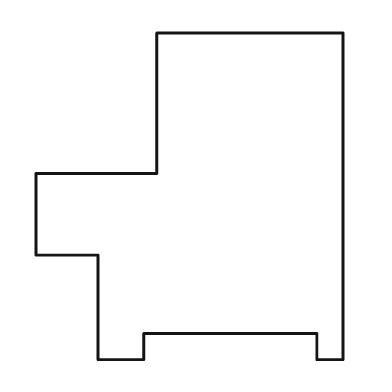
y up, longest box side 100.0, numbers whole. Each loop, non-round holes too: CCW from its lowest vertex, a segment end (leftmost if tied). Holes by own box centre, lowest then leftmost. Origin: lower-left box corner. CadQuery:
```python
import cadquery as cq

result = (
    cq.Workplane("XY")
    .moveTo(19.0, 0.0)
    .lineTo(33.0, 0.0)
    .lineTo(33.0, 8.0)
    .lineTo(86.0, 8.0)
    .lineTo(86.0, 0.0)
    .lineTo(94.0, 0.0)
    .lineTo(94.0, 100.0)
    .lineTo(37.0, 100.0)
    .lineTo(37.0, 57.0)
    .lineTo(0.0, 57.0)
    .lineTo(0.0, 32.0)
    .lineTo(19.0, 32.0)
    .close()
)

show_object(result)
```